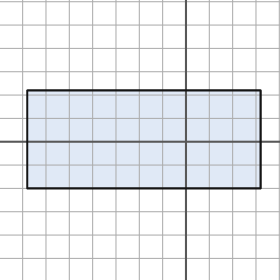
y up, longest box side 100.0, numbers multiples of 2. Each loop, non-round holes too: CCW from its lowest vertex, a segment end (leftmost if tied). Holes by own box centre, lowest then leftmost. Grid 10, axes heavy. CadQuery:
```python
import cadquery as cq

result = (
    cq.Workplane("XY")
    .moveTo(-68.0, -20.0)
    .lineTo(32.0, -20.0)
    .lineTo(32.0, 22.0)
    .lineTo(-68.0, 22.0)
    .close()
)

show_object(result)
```